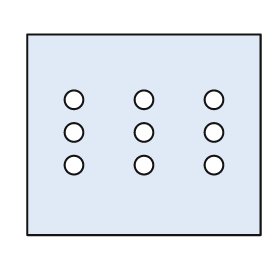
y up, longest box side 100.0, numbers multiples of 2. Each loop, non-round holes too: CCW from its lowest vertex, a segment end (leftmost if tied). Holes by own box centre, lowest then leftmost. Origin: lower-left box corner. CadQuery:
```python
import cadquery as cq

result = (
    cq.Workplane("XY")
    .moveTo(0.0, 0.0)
    .lineTo(100.0, 0.0)
    .lineTo(100.0, 86.0)
    .lineTo(0.0, 86.0)
    .close()
    .moveTo(20.0, 30.0)
    .circle(4.0)
    .moveTo(50.0, 30.0)
    .circle(4.0)
    .moveTo(80.0, 30.0)
    .circle(4.0)
    .moveTo(20.0, 44.0)
    .circle(4.0)
    .moveTo(50.0, 44.0)
    .circle(4.0)
    .moveTo(80.0, 44.0)
    .circle(4.0)
    .moveTo(20.0, 58.0)
    .circle(4.0)
    .moveTo(50.0, 58.0)
    .circle(4.0)
    .moveTo(80.0, 58.0)
    .circle(4.0)
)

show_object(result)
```